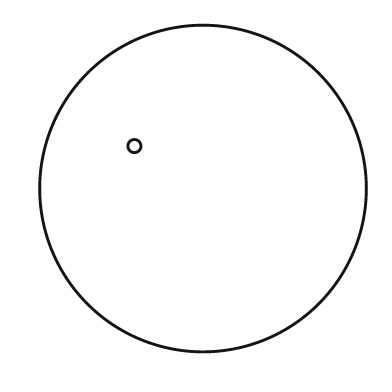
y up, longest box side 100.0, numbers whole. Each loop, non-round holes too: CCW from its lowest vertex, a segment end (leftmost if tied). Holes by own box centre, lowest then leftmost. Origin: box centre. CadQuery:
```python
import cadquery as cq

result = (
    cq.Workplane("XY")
    .moveTo(0.0, 0.0)
    .circle(50.0)
    .moveTo(-21.0, 13.0)
    .circle(2.0)
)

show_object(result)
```